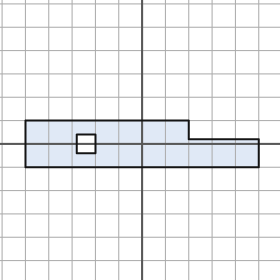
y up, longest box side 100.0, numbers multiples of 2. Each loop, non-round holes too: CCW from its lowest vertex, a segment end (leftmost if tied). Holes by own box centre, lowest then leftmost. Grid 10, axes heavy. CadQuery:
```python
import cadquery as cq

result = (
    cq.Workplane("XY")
    .moveTo(-50.0, -10.0)
    .lineTo(50.0, -10.0)
    .lineTo(50.0, 2.0)
    .lineTo(20.0, 2.0)
    .lineTo(20.0, 10.0)
    .lineTo(-50.0, 10.0)
    .close()
    .moveTo(-28.0, -4.0)
    .lineTo(-20.0, -4.0)
    .lineTo(-20.0, 4.0)
    .lineTo(-28.0, 4.0)
    .close()
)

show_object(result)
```